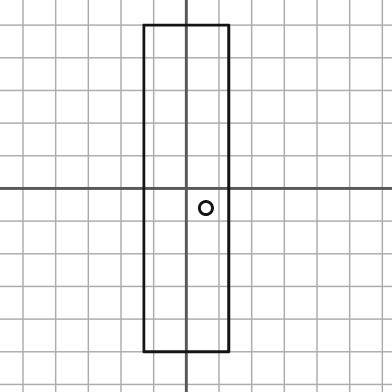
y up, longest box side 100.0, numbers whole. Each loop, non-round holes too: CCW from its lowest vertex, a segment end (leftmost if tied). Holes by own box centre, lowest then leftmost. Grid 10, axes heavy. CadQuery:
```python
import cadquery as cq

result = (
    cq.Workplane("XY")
    .moveTo(-13.0, -50.0)
    .lineTo(13.0, -50.0)
    .lineTo(13.0, 50.0)
    .lineTo(-13.0, 50.0)
    .close()
    .moveTo(6.0, -6.0)
    .circle(2.0)
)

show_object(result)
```